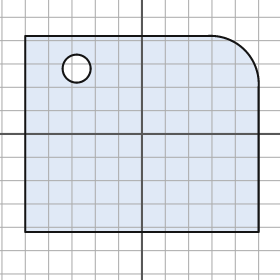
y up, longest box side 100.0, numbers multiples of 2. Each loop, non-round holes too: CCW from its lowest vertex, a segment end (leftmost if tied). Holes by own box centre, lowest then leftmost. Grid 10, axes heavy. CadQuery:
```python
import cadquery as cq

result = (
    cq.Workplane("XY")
    .moveTo(-50.0, -42.0)
    .lineTo(50.0, -42.0)
    .lineTo(50.0, 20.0)
    .threePointArc((44.0, 36.0), (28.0, 42.0))
    .lineTo(-50.0, 42.0)
    .close()
    .moveTo(-28.0, 28.0)
    .circle(6.0)
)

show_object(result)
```